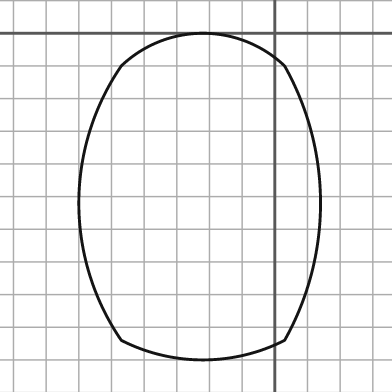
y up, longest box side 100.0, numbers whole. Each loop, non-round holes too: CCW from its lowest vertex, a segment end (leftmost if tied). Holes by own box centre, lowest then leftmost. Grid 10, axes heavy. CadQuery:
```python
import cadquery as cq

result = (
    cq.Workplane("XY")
    .moveTo(-47.0, -94.0)
    .threePointArc((-22.0, -100.0), (3.0, -94.0))
    .threePointArc((14.0, -52.0), (3.0, -10.0))
    .threePointArc((-22.0, 0.0), (-47.0, -10.0))
    .threePointArc((-60.0, -52.0), (-47.0, -94.0))
    .close()
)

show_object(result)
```